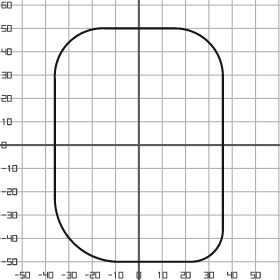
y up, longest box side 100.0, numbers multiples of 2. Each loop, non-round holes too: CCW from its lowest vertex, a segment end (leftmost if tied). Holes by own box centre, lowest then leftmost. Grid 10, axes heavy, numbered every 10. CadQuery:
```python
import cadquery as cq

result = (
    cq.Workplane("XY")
    .moveTo(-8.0, -50.0)
    .lineTo(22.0, -50.0)
    .threePointArc((32.0, -46.0), (36.0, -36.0))
    .lineTo(36.0, 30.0)
    .threePointArc((30.0, 44.0), (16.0, 50.0))
    .lineTo(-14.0, 50.0)
    .threePointArc((-30.0, 44.0), (-36.0, 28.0))
    .lineTo(-36.0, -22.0)
    .threePointArc((-28.0, -42.0), (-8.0, -50.0))
    .close()
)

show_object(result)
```